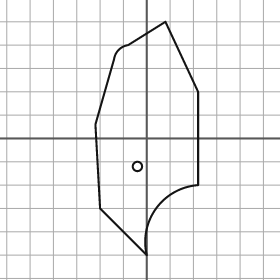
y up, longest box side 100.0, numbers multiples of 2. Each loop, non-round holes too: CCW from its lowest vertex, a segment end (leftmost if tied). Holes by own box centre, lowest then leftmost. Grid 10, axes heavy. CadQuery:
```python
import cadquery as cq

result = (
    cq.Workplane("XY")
    .moveTo(0.0, -50.0)
    .threePointArc((4.0, -30.0), (22.0, -20.0))
    .lineTo(22.0, 20.0)
    .lineTo(8.0, 50.0)
    .lineTo(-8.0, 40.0)
    .threePointArc((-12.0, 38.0), (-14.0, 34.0))
    .lineTo(-22.0, 6.0)
    .lineTo(-20.0, -30.0)
    .close()
    .moveTo(-4.0, -12.0)
    .circle(2.0)
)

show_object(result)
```